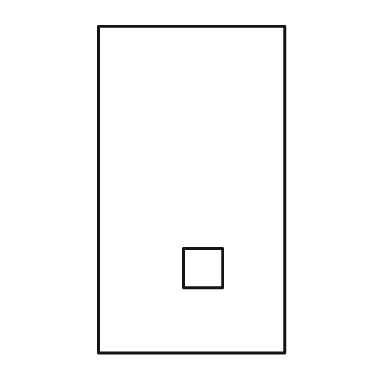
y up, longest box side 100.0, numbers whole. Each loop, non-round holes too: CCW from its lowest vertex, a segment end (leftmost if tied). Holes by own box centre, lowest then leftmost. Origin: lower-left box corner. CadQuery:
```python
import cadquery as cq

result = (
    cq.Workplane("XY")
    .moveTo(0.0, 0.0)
    .lineTo(57.0, 0.0)
    .lineTo(57.0, 100.0)
    .lineTo(0.0, 100.0)
    .close()
    .moveTo(26.0, 20.0)
    .lineTo(38.0, 20.0)
    .lineTo(38.0, 32.0)
    .lineTo(26.0, 32.0)
    .close()
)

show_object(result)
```